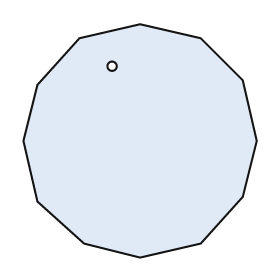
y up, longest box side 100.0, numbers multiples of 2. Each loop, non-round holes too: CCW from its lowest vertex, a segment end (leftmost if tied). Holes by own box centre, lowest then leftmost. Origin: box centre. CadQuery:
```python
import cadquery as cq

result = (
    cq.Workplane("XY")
    .moveTo(0.0, -50.0)
    .lineTo(26.0, -44.0)
    .lineTo(44.0, -24.0)
    .lineTo(50.0, 0.0)
    .lineTo(44.0, 26.0)
    .lineTo(26.0, 44.0)
    .lineTo(0.0, 50.0)
    .lineTo(-26.0, 44.0)
    .lineTo(-44.0, 24.0)
    .lineTo(-50.0, 0.0)
    .lineTo(-44.0, -26.0)
    .lineTo(-24.0, -44.0)
    .close()
    .moveTo(-12.0, 32.0)
    .circle(2.0)
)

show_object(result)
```